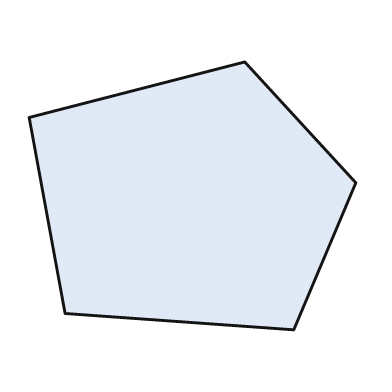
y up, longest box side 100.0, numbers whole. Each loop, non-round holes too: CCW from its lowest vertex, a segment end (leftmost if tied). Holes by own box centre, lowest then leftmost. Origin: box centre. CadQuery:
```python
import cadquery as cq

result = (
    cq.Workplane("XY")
    .moveTo(31.0, -41.0)
    .lineTo(50.0, 4.0)
    .lineTo(16.0, 41.0)
    .lineTo(-50.0, 24.0)
    .lineTo(-39.0, -36.0)
    .close()
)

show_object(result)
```